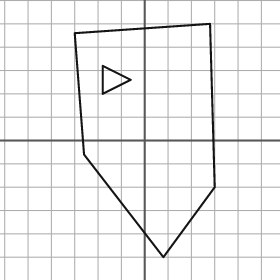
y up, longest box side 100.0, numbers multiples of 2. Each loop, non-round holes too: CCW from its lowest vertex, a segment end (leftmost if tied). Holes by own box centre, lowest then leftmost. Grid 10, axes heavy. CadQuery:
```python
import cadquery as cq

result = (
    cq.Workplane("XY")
    .moveTo(8.0, -50.0)
    .lineTo(30.0, -20.0)
    .lineTo(28.0, 50.0)
    .lineTo(-30.0, 46.0)
    .lineTo(-26.0, -6.0)
    .close()
    .moveTo(-18.0, 20.0)
    .lineTo(-6.0, 26.0)
    .lineTo(-18.0, 32.0)
    .close()
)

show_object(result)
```